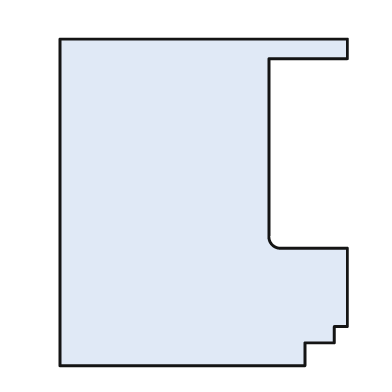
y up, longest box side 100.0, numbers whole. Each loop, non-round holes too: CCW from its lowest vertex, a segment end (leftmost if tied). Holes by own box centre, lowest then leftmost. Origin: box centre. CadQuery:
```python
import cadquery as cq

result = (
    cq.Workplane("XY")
    .moveTo(-44.0, -50.0)
    .lineTo(31.0, -50.0)
    .lineTo(31.0, -43.0)
    .lineTo(40.0, -43.0)
    .lineTo(40.0, -38.0)
    .lineTo(44.0, -38.0)
    .lineTo(44.0, -14.0)
    .lineTo(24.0, -14.0)
    .threePointArc((21.0, -13.0), (20.0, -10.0))
    .lineTo(20.0, 44.0)
    .lineTo(44.0, 44.0)
    .lineTo(44.0, 50.0)
    .lineTo(-44.0, 50.0)
    .close()
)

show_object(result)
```